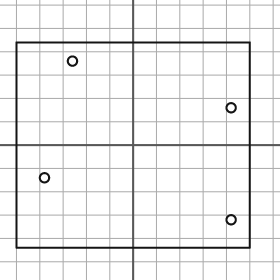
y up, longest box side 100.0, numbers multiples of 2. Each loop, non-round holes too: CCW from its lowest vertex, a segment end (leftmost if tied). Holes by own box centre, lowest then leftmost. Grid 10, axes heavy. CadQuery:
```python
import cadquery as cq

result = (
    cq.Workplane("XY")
    .moveTo(-50.0, -44.0)
    .lineTo(50.0, -44.0)
    .lineTo(50.0, 44.0)
    .lineTo(-50.0, 44.0)
    .close()
    .moveTo(42.0, -32.0)
    .circle(2.0)
    .moveTo(-38.0, -14.0)
    .circle(2.0)
    .moveTo(42.0, 16.0)
    .circle(2.0)
    .moveTo(-26.0, 36.0)
    .circle(2.0)
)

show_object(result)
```